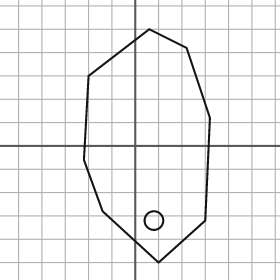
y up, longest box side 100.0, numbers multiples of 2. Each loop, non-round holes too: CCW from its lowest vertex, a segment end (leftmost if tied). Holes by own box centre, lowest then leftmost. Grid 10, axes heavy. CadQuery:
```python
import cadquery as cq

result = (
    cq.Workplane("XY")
    .moveTo(10.0, -50.0)
    .lineTo(30.0, -32.0)
    .lineTo(32.0, 12.0)
    .lineTo(22.0, 42.0)
    .lineTo(6.0, 50.0)
    .lineTo(-20.0, 30.0)
    .lineTo(-22.0, -6.0)
    .lineTo(-14.0, -28.0)
    .close()
    .moveTo(8.0, -32.0)
    .circle(4.0)
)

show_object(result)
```